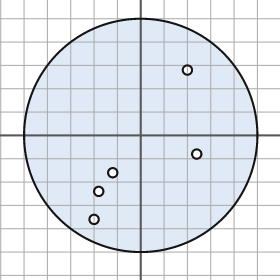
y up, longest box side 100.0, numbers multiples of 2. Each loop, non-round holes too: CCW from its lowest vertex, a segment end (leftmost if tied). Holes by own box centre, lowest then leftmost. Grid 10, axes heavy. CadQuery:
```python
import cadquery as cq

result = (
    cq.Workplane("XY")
    .moveTo(0.0, 0.0)
    .circle(50.0)
    .moveTo(-20.0, -36.0)
    .circle(2.0)
    .moveTo(-18.0, -24.0)
    .circle(2.0)
    .moveTo(-12.0, -16.0)
    .circle(2.0)
    .moveTo(24.0, -8.0)
    .circle(2.0)
    .moveTo(20.0, 28.0)
    .circle(2.0)
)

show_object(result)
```